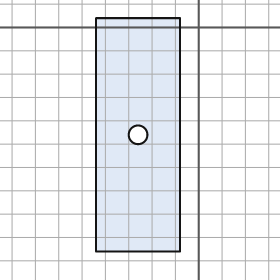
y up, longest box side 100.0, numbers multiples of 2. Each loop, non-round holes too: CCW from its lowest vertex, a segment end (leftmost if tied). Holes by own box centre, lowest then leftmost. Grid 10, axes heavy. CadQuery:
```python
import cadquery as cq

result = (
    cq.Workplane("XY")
    .moveTo(-44.0, -96.0)
    .lineTo(-8.0, -96.0)
    .lineTo(-8.0, 4.0)
    .lineTo(-44.0, 4.0)
    .close()
    .moveTo(-26.0, -46.0)
    .circle(4.0)
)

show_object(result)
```